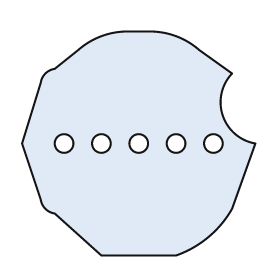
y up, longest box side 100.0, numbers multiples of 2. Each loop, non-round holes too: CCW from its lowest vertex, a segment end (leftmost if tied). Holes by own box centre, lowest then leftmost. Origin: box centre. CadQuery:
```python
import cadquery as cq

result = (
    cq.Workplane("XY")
    .moveTo(-16.0, -48.0)
    .lineTo(16.0, -48.0)
    .threePointArc((30.0, -40.0), (40.0, -28.0))
    .lineTo(50.0, 0.0)
    .threePointArc((36.0, 12.0), (40.0, 30.0))
    .lineTo(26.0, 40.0)
    .threePointArc((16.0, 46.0), (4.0, 48.0))
    .lineTo(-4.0, 48.0)
    .threePointArc((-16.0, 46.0), (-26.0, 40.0))
    .lineTo(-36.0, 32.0)
    .threePointArc((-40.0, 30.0), (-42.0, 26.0))
    .lineTo(-50.0, 0.0)
    .lineTo(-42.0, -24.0)
    .threePointArc((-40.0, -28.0), (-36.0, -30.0))
    .close()
    .moveTo(-32.0, 0.0)
    .circle(4.0)
    .moveTo(-16.0, 0.0)
    .circle(4.0)
    .moveTo(0.0, 0.0)
    .circle(4.0)
    .moveTo(16.0, 0.0)
    .circle(4.0)
    .moveTo(32.0, 0.0)
    .circle(4.0)
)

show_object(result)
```